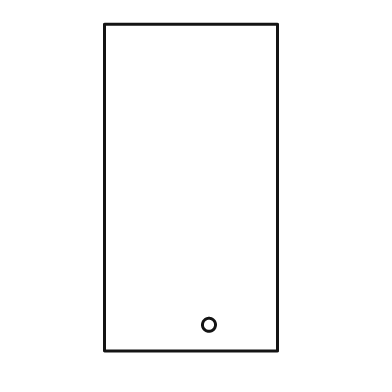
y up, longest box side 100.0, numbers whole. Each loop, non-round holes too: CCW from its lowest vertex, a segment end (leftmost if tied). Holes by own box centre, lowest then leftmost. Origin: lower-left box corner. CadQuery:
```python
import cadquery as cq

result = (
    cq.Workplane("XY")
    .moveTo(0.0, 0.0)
    .lineTo(53.0, 0.0)
    .lineTo(53.0, 100.0)
    .lineTo(0.0, 100.0)
    .close()
    .moveTo(32.0, 8.0)
    .circle(2.0)
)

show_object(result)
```